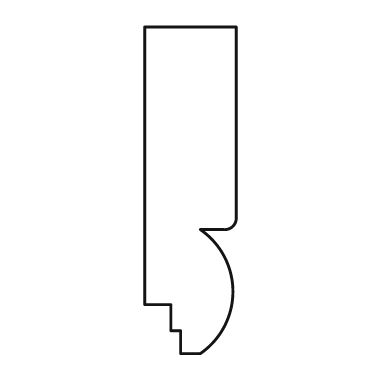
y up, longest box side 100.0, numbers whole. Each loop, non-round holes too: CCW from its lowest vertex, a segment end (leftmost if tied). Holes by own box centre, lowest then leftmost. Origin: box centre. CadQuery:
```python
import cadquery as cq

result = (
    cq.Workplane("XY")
    .moveTo(-3.0, -50.0)
    .lineTo(3.0, -50.0)
    .threePointArc((13.0, -31.0), (3.0, -12.0))
    .lineTo(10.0, -12.0)
    .threePointArc((13.0, -11.0), (14.0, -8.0))
    .lineTo(14.0, 50.0)
    .lineTo(-14.0, 50.0)
    .lineTo(-14.0, -35.0)
    .lineTo(-6.0, -35.0)
    .lineTo(-6.0, -43.0)
    .lineTo(-3.0, -43.0)
    .close()
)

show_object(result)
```